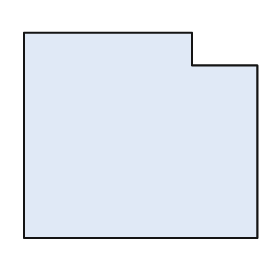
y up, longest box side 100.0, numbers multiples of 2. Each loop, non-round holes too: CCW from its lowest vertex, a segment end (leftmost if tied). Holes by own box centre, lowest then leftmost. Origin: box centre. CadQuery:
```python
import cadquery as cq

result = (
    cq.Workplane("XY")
    .moveTo(-50.0, -44.0)
    .lineTo(50.0, -44.0)
    .lineTo(50.0, 30.0)
    .lineTo(22.0, 30.0)
    .lineTo(22.0, 44.0)
    .lineTo(-50.0, 44.0)
    .close()
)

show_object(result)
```